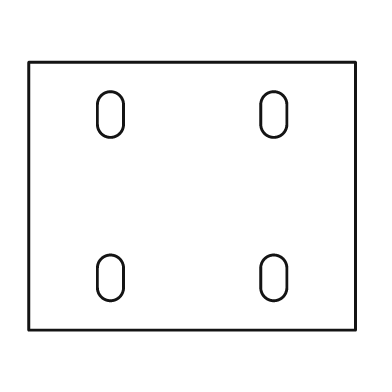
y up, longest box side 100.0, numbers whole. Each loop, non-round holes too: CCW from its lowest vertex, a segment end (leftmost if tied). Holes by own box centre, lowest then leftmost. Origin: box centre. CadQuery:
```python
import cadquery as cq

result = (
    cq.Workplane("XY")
    .moveTo(-50.0, -41.0)
    .lineTo(50.0, -41.0)
    .lineTo(50.0, 41.0)
    .lineTo(-50.0, 41.0)
    .close()
    .moveTo(-29.0, -28.0)
    .threePointArc((-25.0, -32.0), (-21.0, -28.0))
    .lineTo(-21.0, -22.0)
    .threePointArc((-25.0, -18.0), (-29.0, -22.0))
    .close()
    .moveTo(21.0, -28.0)
    .threePointArc((25.0, -32.0), (29.0, -28.0))
    .lineTo(29.0, -22.0)
    .threePointArc((25.0, -18.0), (21.0, -22.0))
    .close()
    .moveTo(-29.0, 22.0)
    .threePointArc((-25.0, 18.0), (-21.0, 22.0))
    .lineTo(-21.0, 28.0)
    .threePointArc((-25.0, 32.0), (-29.0, 28.0))
    .close()
    .moveTo(21.0, 22.0)
    .threePointArc((25.0, 18.0), (29.0, 22.0))
    .lineTo(29.0, 28.0)
    .threePointArc((25.0, 32.0), (21.0, 28.0))
    .close()
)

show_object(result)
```